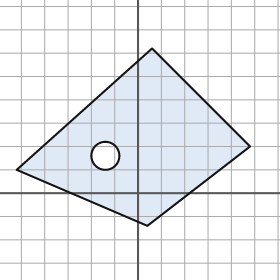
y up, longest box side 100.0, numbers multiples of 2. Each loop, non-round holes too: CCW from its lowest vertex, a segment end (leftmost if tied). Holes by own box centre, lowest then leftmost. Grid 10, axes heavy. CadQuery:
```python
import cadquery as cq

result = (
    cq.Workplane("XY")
    .moveTo(4.0, -14.0)
    .lineTo(48.0, 20.0)
    .lineTo(6.0, 62.0)
    .lineTo(-52.0, 10.0)
    .close()
    .moveTo(-14.0, 16.0)
    .circle(6.0)
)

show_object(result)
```